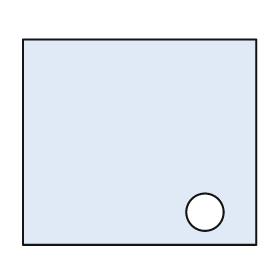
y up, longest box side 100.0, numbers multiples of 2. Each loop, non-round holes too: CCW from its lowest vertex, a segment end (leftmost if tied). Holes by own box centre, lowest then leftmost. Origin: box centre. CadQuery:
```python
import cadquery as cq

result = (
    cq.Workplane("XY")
    .moveTo(-50.0, -44.0)
    .lineTo(50.0, -44.0)
    .lineTo(50.0, 44.0)
    .lineTo(-50.0, 44.0)
    .close()
    .moveTo(28.0, -30.0)
    .circle(8.0)
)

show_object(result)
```